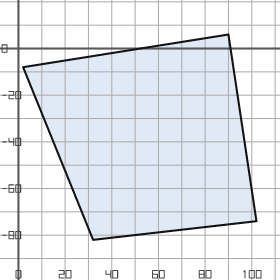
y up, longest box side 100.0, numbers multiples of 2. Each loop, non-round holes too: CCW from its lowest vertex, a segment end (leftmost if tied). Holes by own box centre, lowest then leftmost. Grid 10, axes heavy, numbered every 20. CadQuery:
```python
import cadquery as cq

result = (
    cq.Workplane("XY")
    .moveTo(32.0, -82.0)
    .lineTo(102.0, -74.0)
    .lineTo(90.0, 6.0)
    .lineTo(2.0, -8.0)
    .close()
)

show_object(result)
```